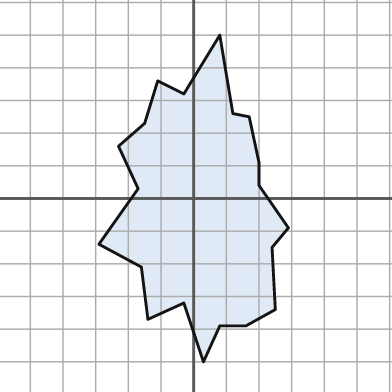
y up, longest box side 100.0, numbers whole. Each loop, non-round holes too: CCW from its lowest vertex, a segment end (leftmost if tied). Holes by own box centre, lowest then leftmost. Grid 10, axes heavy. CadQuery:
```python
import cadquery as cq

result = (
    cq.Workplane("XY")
    .moveTo(3.0, -50.0)
    .lineTo(8.0, -39.0)
    .lineTo(16.0, -39.0)
    .lineTo(25.0, -34.0)
    .lineTo(24.0, -15.0)
    .lineTo(29.0, -9.0)
    .lineTo(20.0, 4.0)
    .lineTo(20.0, 11.0)
    .lineTo(17.0, 25.0)
    .lineTo(12.0, 26.0)
    .lineTo(8.0, 50.0)
    .lineTo(-3.0, 32.0)
    .lineTo(-11.0, 36.0)
    .lineTo(-15.0, 23.0)
    .lineTo(-23.0, 16.0)
    .lineTo(-17.0, 3.0)
    .lineTo(-29.0, -14.0)
    .lineTo(-16.0, -21.0)
    .lineTo(-14.0, -37.0)
    .lineTo(-3.0, -32.0)
    .close()
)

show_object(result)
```